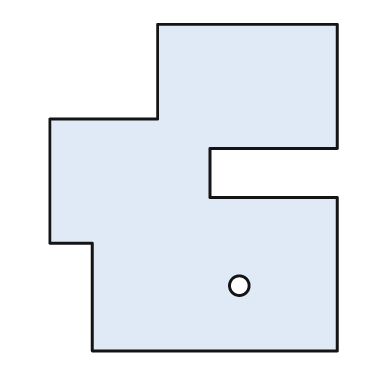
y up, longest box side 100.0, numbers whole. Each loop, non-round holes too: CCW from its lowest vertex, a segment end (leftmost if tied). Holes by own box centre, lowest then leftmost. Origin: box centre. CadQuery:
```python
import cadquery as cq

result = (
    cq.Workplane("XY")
    .moveTo(-31.0, -50.0)
    .lineTo(44.0, -50.0)
    .lineTo(44.0, -3.0)
    .lineTo(5.0, -3.0)
    .lineTo(5.0, 12.0)
    .lineTo(44.0, 12.0)
    .lineTo(44.0, 50.0)
    .lineTo(-11.0, 50.0)
    .lineTo(-11.0, 21.0)
    .lineTo(-44.0, 21.0)
    .lineTo(-44.0, -17.0)
    .lineTo(-31.0, -17.0)
    .close()
    .moveTo(14.0, -30.0)
    .circle(3.0)
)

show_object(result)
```